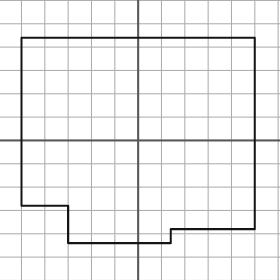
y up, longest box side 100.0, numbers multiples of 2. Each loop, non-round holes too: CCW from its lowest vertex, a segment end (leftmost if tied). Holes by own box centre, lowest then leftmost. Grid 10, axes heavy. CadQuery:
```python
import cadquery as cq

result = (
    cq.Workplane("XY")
    .moveTo(-30.0, -44.0)
    .lineTo(14.0, -44.0)
    .lineTo(14.0, -38.0)
    .lineTo(50.0, -38.0)
    .lineTo(50.0, 44.0)
    .lineTo(-50.0, 44.0)
    .lineTo(-50.0, -28.0)
    .lineTo(-30.0, -28.0)
    .close()
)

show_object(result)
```